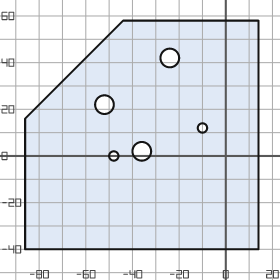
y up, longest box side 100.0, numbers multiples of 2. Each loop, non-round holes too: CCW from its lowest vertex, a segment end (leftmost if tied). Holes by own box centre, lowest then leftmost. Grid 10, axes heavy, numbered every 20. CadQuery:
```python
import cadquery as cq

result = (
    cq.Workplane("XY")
    .moveTo(-86.0, -40.0)
    .lineTo(14.0, -40.0)
    .lineTo(14.0, 58.0)
    .lineTo(-44.0, 58.0)
    .lineTo(-86.0, 16.0)
    .close()
    .moveTo(-48.0, 0.0)
    .circle(2.0)
    .moveTo(-36.0, 2.0)
    .circle(4.0)
    .moveTo(-10.0, 12.0)
    .circle(2.0)
    .moveTo(-52.0, 22.0)
    .circle(4.0)
    .moveTo(-24.0, 42.0)
    .circle(4.0)
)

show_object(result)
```